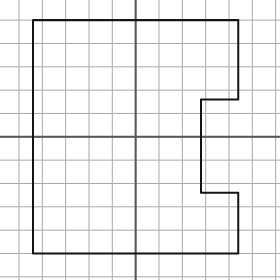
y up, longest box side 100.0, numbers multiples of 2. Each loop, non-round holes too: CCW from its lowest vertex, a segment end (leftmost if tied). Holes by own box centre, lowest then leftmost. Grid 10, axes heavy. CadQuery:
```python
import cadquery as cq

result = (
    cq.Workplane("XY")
    .moveTo(-44.0, -50.0)
    .lineTo(44.0, -50.0)
    .lineTo(44.0, -24.0)
    .lineTo(28.0, -24.0)
    .lineTo(28.0, 16.0)
    .lineTo(44.0, 16.0)
    .lineTo(44.0, 50.0)
    .lineTo(-44.0, 50.0)
    .close()
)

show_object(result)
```